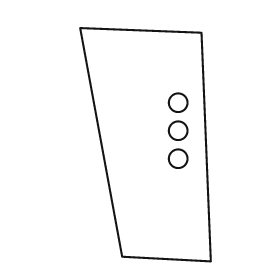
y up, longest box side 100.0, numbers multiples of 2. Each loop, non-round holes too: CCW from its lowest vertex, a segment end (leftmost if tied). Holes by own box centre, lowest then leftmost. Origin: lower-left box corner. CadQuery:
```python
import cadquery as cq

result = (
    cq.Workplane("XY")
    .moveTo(56.0, 0.0)
    .lineTo(52.0, 98.0)
    .lineTo(0.0, 100.0)
    .lineTo(18.0, 2.0)
    .close()
    .moveTo(42.0, 44.0)
    .circle(4.0)
    .moveTo(42.0, 56.0)
    .circle(4.0)
    .moveTo(42.0, 68.0)
    .circle(4.0)
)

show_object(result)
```